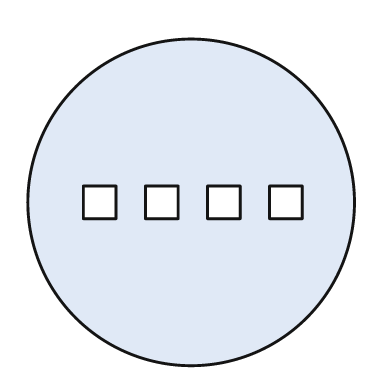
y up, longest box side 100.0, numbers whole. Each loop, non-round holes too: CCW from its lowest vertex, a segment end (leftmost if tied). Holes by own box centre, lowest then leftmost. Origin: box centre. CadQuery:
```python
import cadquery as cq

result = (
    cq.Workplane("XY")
    .moveTo(0.0, 0.0)
    .circle(50.0)
    .moveTo(-33.0, -5.0)
    .lineTo(-23.0, -5.0)
    .lineTo(-23.0, 5.0)
    .lineTo(-33.0, 5.0)
    .close()
    .moveTo(-14.0, -5.0)
    .lineTo(-4.0, -5.0)
    .lineTo(-4.0, 5.0)
    .lineTo(-14.0, 5.0)
    .close()
    .moveTo(5.0, -5.0)
    .lineTo(15.0, -5.0)
    .lineTo(15.0, 5.0)
    .lineTo(5.0, 5.0)
    .close()
    .moveTo(24.0, -5.0)
    .lineTo(34.0, -5.0)
    .lineTo(34.0, 5.0)
    .lineTo(24.0, 5.0)
    .close()
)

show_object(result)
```